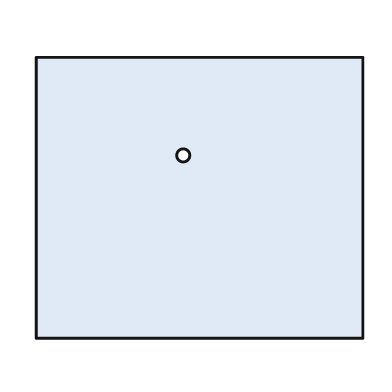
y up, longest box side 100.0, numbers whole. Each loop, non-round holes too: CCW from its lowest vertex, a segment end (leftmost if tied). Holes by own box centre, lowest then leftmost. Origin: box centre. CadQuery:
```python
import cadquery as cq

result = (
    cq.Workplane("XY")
    .moveTo(-50.0, -43.0)
    .lineTo(50.0, -43.0)
    .lineTo(50.0, 43.0)
    .lineTo(-50.0, 43.0)
    .close()
    .moveTo(-5.0, 13.0)
    .circle(2.0)
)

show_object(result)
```